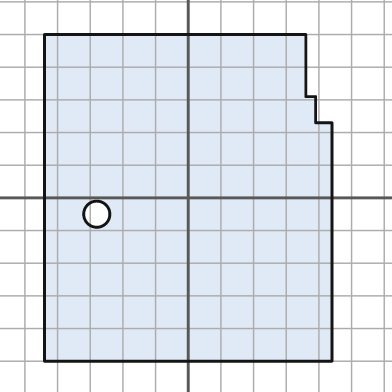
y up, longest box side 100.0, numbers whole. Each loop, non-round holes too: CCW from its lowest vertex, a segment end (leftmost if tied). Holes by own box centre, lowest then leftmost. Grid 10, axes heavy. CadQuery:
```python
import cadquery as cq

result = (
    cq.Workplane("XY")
    .moveTo(-44.0, -50.0)
    .lineTo(44.0, -50.0)
    .lineTo(44.0, 23.0)
    .lineTo(39.0, 23.0)
    .lineTo(39.0, 31.0)
    .lineTo(36.0, 31.0)
    .lineTo(36.0, 50.0)
    .lineTo(-44.0, 50.0)
    .close()
    .moveTo(-28.0, -5.0)
    .circle(4.0)
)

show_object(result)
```